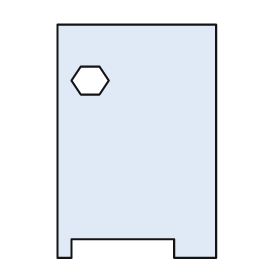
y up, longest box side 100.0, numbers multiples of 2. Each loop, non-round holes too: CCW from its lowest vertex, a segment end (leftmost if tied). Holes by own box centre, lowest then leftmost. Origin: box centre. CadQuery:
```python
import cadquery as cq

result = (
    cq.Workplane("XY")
    .moveTo(-34.0, -50.0)
    .lineTo(-28.0, -50.0)
    .lineTo(-28.0, -42.0)
    .lineTo(16.0, -42.0)
    .lineTo(16.0, -50.0)
    .lineTo(34.0, -50.0)
    .lineTo(34.0, 50.0)
    .lineTo(-34.0, 50.0)
    .close()
    .moveTo(-24.0, 20.0)
    .lineTo(-16.0, 20.0)
    .lineTo(-12.0, 26.0)
    .lineTo(-16.0, 32.0)
    .lineTo(-24.0, 32.0)
    .lineTo(-28.0, 26.0)
    .close()
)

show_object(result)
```